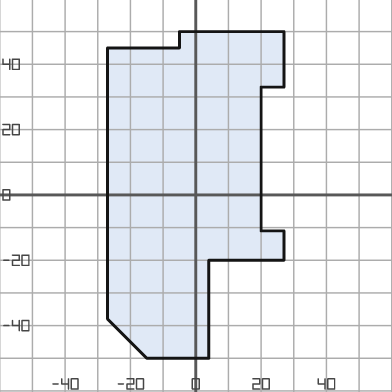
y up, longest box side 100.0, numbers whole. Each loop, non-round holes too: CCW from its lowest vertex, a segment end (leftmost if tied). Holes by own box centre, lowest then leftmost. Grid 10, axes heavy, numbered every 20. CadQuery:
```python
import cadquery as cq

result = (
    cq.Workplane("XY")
    .moveTo(-15.0, -50.0)
    .lineTo(4.0, -50.0)
    .lineTo(4.0, -20.0)
    .lineTo(27.0, -20.0)
    .lineTo(27.0, -11.0)
    .lineTo(20.0, -11.0)
    .lineTo(20.0, 33.0)
    .lineTo(27.0, 33.0)
    .lineTo(27.0, 50.0)
    .lineTo(-5.0, 50.0)
    .lineTo(-5.0, 45.0)
    .lineTo(-27.0, 45.0)
    .lineTo(-27.0, -38.0)
    .close()
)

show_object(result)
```